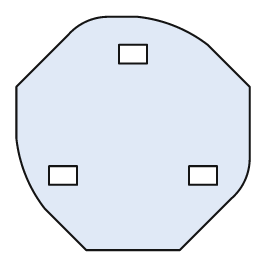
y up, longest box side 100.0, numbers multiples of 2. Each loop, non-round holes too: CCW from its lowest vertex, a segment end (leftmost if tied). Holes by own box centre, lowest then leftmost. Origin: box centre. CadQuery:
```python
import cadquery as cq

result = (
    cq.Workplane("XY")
    .moveTo(-20.0, -50.0)
    .lineTo(20.0, -50.0)
    .lineTo(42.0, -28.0)
    .threePointArc((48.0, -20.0), (50.0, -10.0))
    .lineTo(50.0, 20.0)
    .lineTo(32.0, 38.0)
    .threePointArc((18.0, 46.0), (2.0, 50.0))
    .lineTo(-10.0, 50.0)
    .threePointArc((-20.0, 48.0), (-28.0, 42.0))
    .lineTo(-50.0, 20.0)
    .lineTo(-50.0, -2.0)
    .threePointArc((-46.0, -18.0), (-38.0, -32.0))
    .close()
    .moveTo(-36.0, -22.0)
    .lineTo(-24.0, -22.0)
    .lineTo(-24.0, -14.0)
    .lineTo(-36.0, -14.0)
    .close()
    .moveTo(24.0, -22.0)
    .lineTo(36.0, -22.0)
    .lineTo(36.0, -14.0)
    .lineTo(24.0, -14.0)
    .close()
    .moveTo(-6.0, 30.0)
    .lineTo(6.0, 30.0)
    .lineTo(6.0, 38.0)
    .lineTo(-6.0, 38.0)
    .close()
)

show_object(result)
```